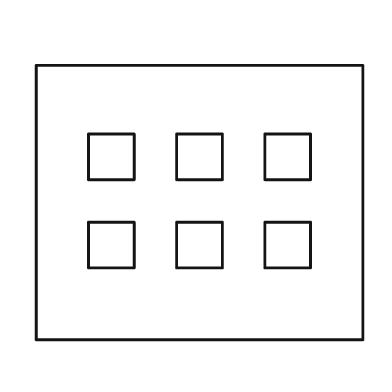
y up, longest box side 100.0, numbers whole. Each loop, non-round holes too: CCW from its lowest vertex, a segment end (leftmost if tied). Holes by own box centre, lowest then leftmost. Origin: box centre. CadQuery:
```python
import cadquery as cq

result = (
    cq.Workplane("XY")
    .moveTo(-50.0, -42.0)
    .lineTo(50.0, -42.0)
    .lineTo(50.0, 42.0)
    .lineTo(-50.0, 42.0)
    .close()
    .moveTo(-34.0, -20.0)
    .lineTo(-20.0, -20.0)
    .lineTo(-20.0, -6.0)
    .lineTo(-34.0, -6.0)
    .close()
    .moveTo(-7.0, -20.0)
    .lineTo(7.0, -20.0)
    .lineTo(7.0, -6.0)
    .lineTo(-7.0, -6.0)
    .close()
    .moveTo(20.0, -20.0)
    .lineTo(34.0, -20.0)
    .lineTo(34.0, -6.0)
    .lineTo(20.0, -6.0)
    .close()
    .moveTo(-34.0, 7.0)
    .lineTo(-20.0, 7.0)
    .lineTo(-20.0, 21.0)
    .lineTo(-34.0, 21.0)
    .close()
    .moveTo(-7.0, 7.0)
    .lineTo(7.0, 7.0)
    .lineTo(7.0, 21.0)
    .lineTo(-7.0, 21.0)
    .close()
    .moveTo(20.0, 7.0)
    .lineTo(34.0, 7.0)
    .lineTo(34.0, 21.0)
    .lineTo(20.0, 21.0)
    .close()
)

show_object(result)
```